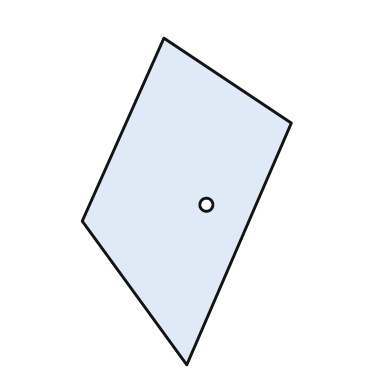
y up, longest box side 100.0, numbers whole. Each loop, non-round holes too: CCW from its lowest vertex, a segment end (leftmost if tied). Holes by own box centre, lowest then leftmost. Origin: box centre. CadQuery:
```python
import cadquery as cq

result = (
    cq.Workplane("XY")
    .moveTo(0.0, -50.0)
    .lineTo(32.0, 24.0)
    .lineTo(-7.0, 50.0)
    .lineTo(-32.0, -6.0)
    .close()
    .moveTo(6.0, -1.0)
    .circle(2.0)
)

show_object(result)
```